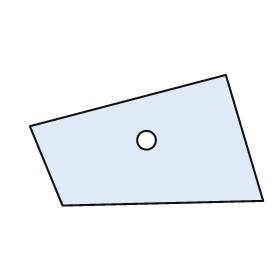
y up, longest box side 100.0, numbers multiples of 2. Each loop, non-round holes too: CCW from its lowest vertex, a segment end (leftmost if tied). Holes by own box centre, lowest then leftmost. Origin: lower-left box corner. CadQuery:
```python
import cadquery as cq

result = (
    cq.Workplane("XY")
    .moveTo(14.0, 0.0)
    .lineTo(100.0, 2.0)
    .lineTo(84.0, 56.0)
    .lineTo(0.0, 34.0)
    .close()
    .moveTo(50.0, 28.0)
    .circle(4.0)
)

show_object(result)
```